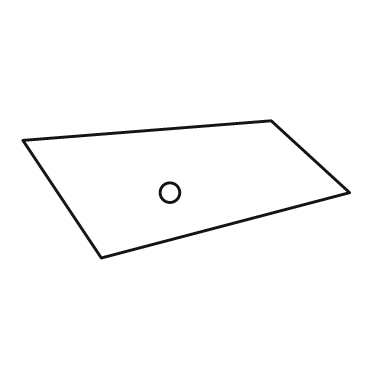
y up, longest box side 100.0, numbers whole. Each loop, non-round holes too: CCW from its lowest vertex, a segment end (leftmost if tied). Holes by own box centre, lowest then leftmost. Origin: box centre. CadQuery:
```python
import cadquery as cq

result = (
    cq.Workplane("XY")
    .moveTo(-26.0, -21.0)
    .lineTo(50.0, -1.0)
    .lineTo(26.0, 21.0)
    .lineTo(-50.0, 15.0)
    .close()
    .moveTo(-5.0, -1.0)
    .circle(3.0)
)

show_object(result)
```